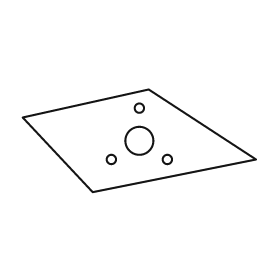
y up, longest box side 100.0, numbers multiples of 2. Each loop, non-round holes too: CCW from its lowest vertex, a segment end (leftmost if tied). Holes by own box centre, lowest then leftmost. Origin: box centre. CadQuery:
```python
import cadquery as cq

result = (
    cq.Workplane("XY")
    .moveTo(-20.0, -22.0)
    .lineTo(50.0, -8.0)
    .lineTo(4.0, 22.0)
    .lineTo(-50.0, 10.0)
    .close()
    .moveTo(-12.0, -8.0)
    .circle(2.0)
    .moveTo(12.0, -8.0)
    .circle(2.0)
    .moveTo(0.0, 0.0)
    .circle(6.0)
    .moveTo(0.0, 14.0)
    .circle(2.0)
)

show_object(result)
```